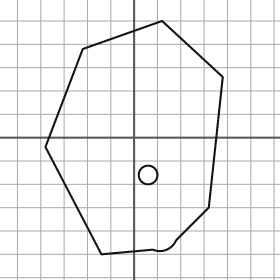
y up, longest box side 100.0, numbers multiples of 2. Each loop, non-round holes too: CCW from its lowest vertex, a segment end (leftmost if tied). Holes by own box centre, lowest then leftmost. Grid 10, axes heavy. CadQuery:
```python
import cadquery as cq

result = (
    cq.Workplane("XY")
    .moveTo(-14.0, -50.0)
    .lineTo(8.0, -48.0)
    .threePointArc((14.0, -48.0), (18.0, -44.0))
    .lineTo(32.0, -30.0)
    .lineTo(38.0, 26.0)
    .lineTo(12.0, 50.0)
    .lineTo(-22.0, 38.0)
    .lineTo(-38.0, -4.0)
    .close()
    .moveTo(6.0, -16.0)
    .circle(4.0)
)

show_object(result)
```